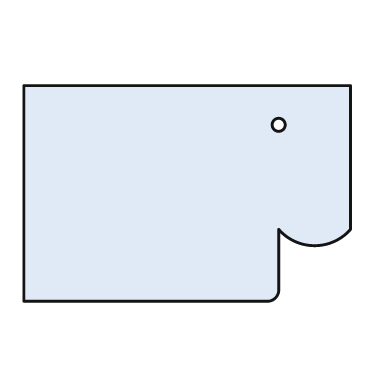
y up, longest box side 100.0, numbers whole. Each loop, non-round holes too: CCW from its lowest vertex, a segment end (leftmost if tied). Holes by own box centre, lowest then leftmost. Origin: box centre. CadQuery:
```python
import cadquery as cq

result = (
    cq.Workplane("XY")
    .moveTo(-50.0, -33.0)
    .lineTo(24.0, -33.0)
    .threePointArc((27.0, -32.0), (28.0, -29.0))
    .lineTo(28.0, -11.0)
    .threePointArc((39.0, -16.0), (50.0, -11.0))
    .lineTo(50.0, 33.0)
    .lineTo(-50.0, 33.0)
    .close()
    .moveTo(28.0, 21.0)
    .circle(2.0)
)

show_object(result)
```